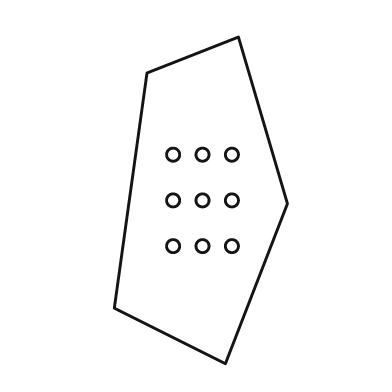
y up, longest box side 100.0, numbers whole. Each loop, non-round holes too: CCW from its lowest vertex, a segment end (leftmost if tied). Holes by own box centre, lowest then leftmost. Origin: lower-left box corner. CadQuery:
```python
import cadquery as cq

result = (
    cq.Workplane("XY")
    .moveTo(34.0, 0.0)
    .lineTo(53.0, 49.0)
    .lineTo(38.0, 100.0)
    .lineTo(10.0, 89.0)
    .lineTo(0.0, 17.0)
    .close()
    .moveTo(18.0, 36.0)
    .circle(2.0)
    .moveTo(27.0, 36.0)
    .circle(2.0)
    .moveTo(36.0, 36.0)
    .circle(2.0)
    .moveTo(18.0, 50.0)
    .circle(2.0)
    .moveTo(27.0, 50.0)
    .circle(2.0)
    .moveTo(36.0, 50.0)
    .circle(2.0)
    .moveTo(18.0, 64.0)
    .circle(2.0)
    .moveTo(27.0, 64.0)
    .circle(2.0)
    .moveTo(36.0, 64.0)
    .circle(2.0)
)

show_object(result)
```